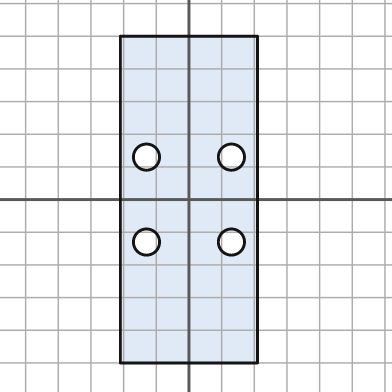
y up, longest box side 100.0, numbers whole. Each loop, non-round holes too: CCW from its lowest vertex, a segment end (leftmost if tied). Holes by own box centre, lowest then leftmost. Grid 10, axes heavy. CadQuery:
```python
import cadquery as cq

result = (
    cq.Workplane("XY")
    .moveTo(-21.0, -50.0)
    .lineTo(21.0, -50.0)
    .lineTo(21.0, 50.0)
    .lineTo(-21.0, 50.0)
    .close()
    .moveTo(-13.0, -13.0)
    .circle(4.0)
    .moveTo(13.0, -13.0)
    .circle(4.0)
    .moveTo(-13.0, 13.0)
    .circle(4.0)
    .moveTo(13.0, 13.0)
    .circle(4.0)
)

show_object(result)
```